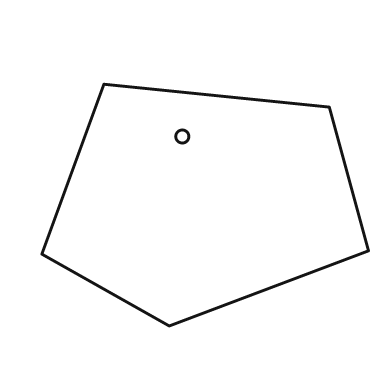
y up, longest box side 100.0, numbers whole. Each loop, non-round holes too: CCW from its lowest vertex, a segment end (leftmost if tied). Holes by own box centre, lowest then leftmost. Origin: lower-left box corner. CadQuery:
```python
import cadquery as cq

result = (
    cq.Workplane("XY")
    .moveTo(39.0, 0.0)
    .lineTo(100.0, 23.0)
    .lineTo(88.0, 67.0)
    .lineTo(19.0, 74.0)
    .lineTo(0.0, 22.0)
    .close()
    .moveTo(43.0, 58.0)
    .circle(2.0)
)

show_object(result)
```